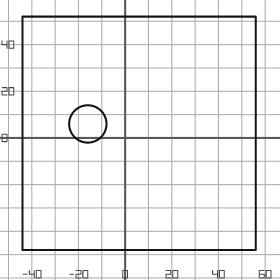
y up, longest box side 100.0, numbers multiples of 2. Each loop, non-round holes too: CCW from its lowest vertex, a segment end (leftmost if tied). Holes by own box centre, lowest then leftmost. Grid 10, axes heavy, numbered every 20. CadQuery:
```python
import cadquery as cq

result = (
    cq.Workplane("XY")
    .moveTo(-44.0, -48.0)
    .lineTo(56.0, -48.0)
    .lineTo(56.0, 52.0)
    .lineTo(-44.0, 52.0)
    .close()
    .moveTo(-16.0, 6.0)
    .circle(8.0)
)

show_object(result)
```